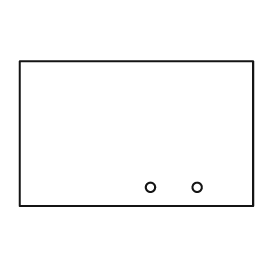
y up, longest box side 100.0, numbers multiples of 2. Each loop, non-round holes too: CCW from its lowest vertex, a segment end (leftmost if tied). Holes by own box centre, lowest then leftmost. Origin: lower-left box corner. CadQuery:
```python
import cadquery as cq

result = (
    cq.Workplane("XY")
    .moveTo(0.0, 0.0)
    .lineTo(100.0, 0.0)
    .lineTo(100.0, 62.0)
    .lineTo(0.0, 62.0)
    .close()
    .moveTo(56.0, 8.0)
    .circle(2.0)
    .moveTo(76.0, 8.0)
    .circle(2.0)
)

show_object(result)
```